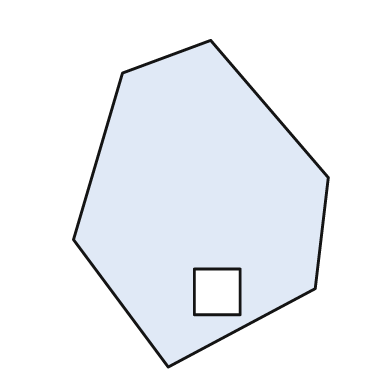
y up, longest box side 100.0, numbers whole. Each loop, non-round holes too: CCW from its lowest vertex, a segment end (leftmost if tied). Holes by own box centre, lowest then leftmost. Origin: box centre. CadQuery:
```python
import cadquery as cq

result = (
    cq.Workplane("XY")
    .moveTo(-10.0, -50.0)
    .lineTo(35.0, -26.0)
    .lineTo(39.0, 8.0)
    .lineTo(3.0, 50.0)
    .lineTo(-24.0, 40.0)
    .lineTo(-39.0, -11.0)
    .close()
    .moveTo(-2.0, -34.0)
    .lineTo(12.0, -34.0)
    .lineTo(12.0, -20.0)
    .lineTo(-2.0, -20.0)
    .close()
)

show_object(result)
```